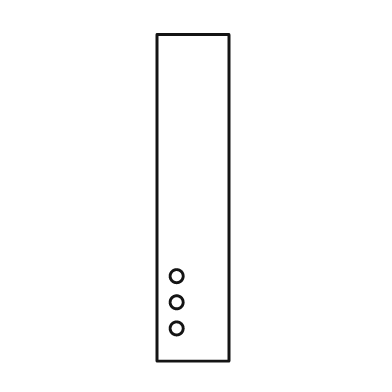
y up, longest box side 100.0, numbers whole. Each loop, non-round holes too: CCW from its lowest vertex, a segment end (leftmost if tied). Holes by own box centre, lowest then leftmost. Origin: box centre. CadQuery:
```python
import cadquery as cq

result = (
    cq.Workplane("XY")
    .moveTo(-11.0, -50.0)
    .lineTo(11.0, -50.0)
    .lineTo(11.0, 50.0)
    .lineTo(-11.0, 50.0)
    .close()
    .moveTo(-5.0, -40.0)
    .circle(2.0)
    .moveTo(-5.0, -32.0)
    .circle(2.0)
    .moveTo(-5.0, -24.0)
    .circle(2.0)
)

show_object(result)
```